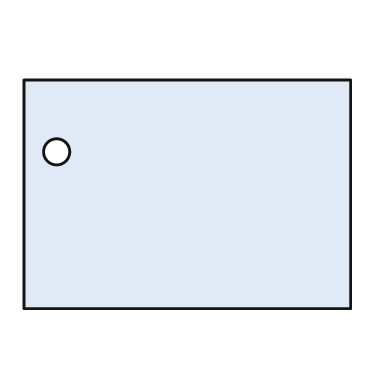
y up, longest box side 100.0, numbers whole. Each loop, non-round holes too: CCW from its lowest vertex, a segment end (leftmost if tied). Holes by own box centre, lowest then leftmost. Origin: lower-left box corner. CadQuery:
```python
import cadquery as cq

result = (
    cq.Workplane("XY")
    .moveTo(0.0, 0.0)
    .lineTo(100.0, 0.0)
    .lineTo(100.0, 70.0)
    .lineTo(0.0, 70.0)
    .close()
    .moveTo(10.0, 48.0)
    .circle(4.0)
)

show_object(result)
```